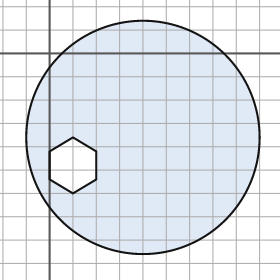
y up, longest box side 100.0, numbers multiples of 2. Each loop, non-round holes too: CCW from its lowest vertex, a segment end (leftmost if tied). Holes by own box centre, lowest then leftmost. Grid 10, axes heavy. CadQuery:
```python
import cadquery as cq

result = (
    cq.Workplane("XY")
    .moveTo(40.0, -36.0)
    .circle(50.0)
    .moveTo(10.0, -60.0)
    .lineTo(20.0, -54.0)
    .lineTo(20.0, -42.0)
    .lineTo(10.0, -36.0)
    .lineTo(0.0, -42.0)
    .lineTo(0.0, -54.0)
    .close()
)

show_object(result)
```